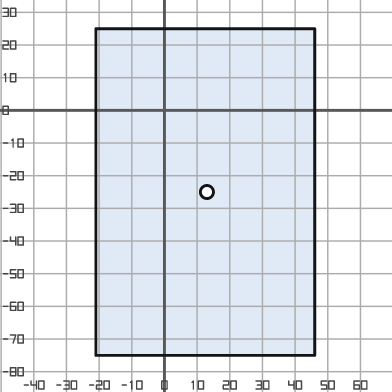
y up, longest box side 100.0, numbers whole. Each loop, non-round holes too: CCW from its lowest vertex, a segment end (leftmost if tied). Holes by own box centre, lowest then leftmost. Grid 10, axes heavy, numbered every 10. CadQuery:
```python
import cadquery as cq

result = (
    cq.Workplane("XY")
    .moveTo(-21.0, -75.0)
    .lineTo(46.0, -75.0)
    .lineTo(46.0, 25.0)
    .lineTo(-21.0, 25.0)
    .close()
    .moveTo(13.0, -25.0)
    .circle(2.0)
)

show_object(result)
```